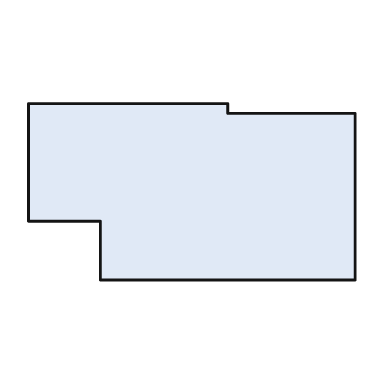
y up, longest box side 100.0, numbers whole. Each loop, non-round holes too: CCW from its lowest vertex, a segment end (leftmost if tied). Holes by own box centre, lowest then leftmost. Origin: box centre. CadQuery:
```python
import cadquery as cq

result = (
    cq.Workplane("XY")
    .moveTo(-28.0, -27.0)
    .lineTo(50.0, -27.0)
    .lineTo(50.0, 24.0)
    .lineTo(11.0, 24.0)
    .lineTo(11.0, 27.0)
    .lineTo(-50.0, 27.0)
    .lineTo(-50.0, -9.0)
    .lineTo(-28.0, -9.0)
    .close()
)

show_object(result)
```